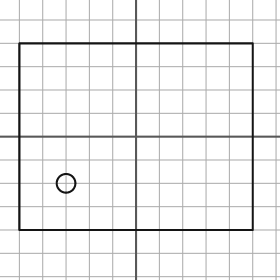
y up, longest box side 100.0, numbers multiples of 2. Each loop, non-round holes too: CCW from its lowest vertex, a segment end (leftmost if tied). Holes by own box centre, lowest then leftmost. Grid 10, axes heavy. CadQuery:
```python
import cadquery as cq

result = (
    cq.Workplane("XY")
    .moveTo(-50.0, -40.0)
    .lineTo(50.0, -40.0)
    .lineTo(50.0, 40.0)
    .lineTo(-50.0, 40.0)
    .close()
    .moveTo(-30.0, -20.0)
    .circle(4.0)
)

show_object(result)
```